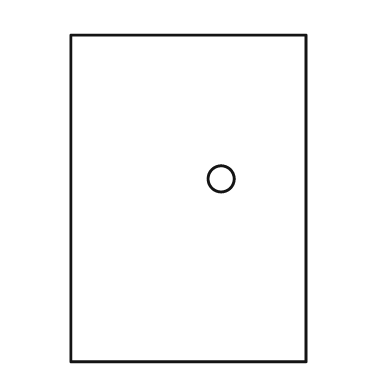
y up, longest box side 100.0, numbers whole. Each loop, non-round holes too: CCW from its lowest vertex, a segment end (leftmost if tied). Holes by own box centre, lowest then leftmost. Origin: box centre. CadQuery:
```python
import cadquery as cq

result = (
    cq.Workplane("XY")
    .moveTo(-36.0, -50.0)
    .lineTo(36.0, -50.0)
    .lineTo(36.0, 50.0)
    .lineTo(-36.0, 50.0)
    .close()
    .moveTo(10.0, 6.0)
    .circle(4.0)
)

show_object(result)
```